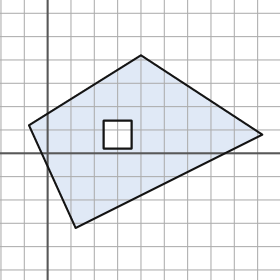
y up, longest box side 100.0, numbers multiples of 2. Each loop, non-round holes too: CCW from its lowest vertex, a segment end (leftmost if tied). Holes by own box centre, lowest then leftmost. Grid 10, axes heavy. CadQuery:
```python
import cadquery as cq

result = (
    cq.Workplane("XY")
    .moveTo(12.0, -32.0)
    .lineTo(92.0, 8.0)
    .lineTo(40.0, 42.0)
    .lineTo(-8.0, 12.0)
    .close()
    .moveTo(24.0, 2.0)
    .lineTo(36.0, 2.0)
    .lineTo(36.0, 14.0)
    .lineTo(24.0, 14.0)
    .close()
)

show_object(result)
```